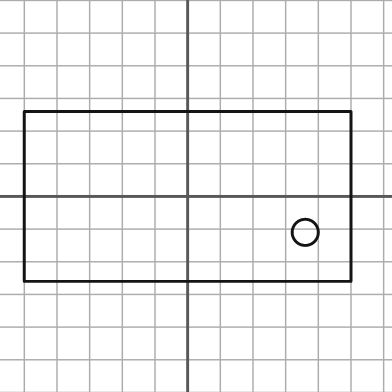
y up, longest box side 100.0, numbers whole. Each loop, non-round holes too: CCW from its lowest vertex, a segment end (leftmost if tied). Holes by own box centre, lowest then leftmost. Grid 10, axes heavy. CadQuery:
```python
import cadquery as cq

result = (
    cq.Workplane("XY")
    .moveTo(-50.0, -26.0)
    .lineTo(50.0, -26.0)
    .lineTo(50.0, 26.0)
    .lineTo(-50.0, 26.0)
    .close()
    .moveTo(36.0, -11.0)
    .circle(4.0)
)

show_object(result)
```